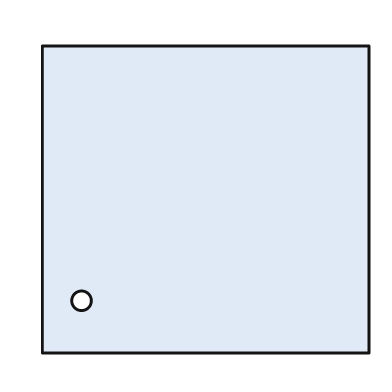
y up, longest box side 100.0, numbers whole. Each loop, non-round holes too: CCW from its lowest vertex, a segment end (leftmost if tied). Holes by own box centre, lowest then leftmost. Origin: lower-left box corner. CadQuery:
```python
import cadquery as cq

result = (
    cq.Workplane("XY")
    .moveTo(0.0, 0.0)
    .lineTo(100.0, 0.0)
    .lineTo(100.0, 94.0)
    .lineTo(0.0, 94.0)
    .close()
    .moveTo(12.0, 16.0)
    .circle(3.0)
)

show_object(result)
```